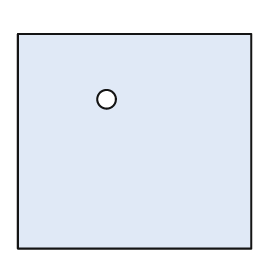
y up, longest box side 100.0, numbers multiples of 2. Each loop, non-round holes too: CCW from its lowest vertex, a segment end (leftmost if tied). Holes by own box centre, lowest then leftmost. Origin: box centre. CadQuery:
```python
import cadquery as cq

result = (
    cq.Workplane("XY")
    .moveTo(-50.0, -46.0)
    .lineTo(50.0, -46.0)
    .lineTo(50.0, 46.0)
    .lineTo(-50.0, 46.0)
    .close()
    .moveTo(-12.0, 18.0)
    .circle(4.0)
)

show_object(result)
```